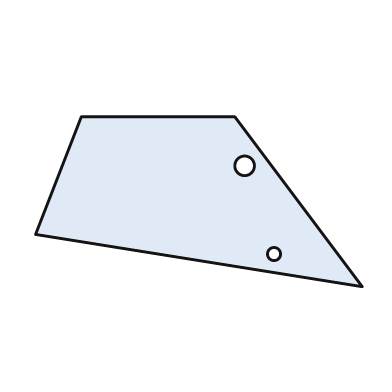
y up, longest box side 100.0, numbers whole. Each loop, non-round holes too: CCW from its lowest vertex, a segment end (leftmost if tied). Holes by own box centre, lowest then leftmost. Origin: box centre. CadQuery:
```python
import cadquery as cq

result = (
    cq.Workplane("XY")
    .moveTo(50.0, -26.0)
    .lineTo(11.0, 26.0)
    .lineTo(-36.0, 26.0)
    .lineTo(-50.0, -10.0)
    .close()
    .moveTo(23.0, -16.0)
    .circle(2.0)
    .moveTo(14.0, 11.0)
    .circle(3.0)
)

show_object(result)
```